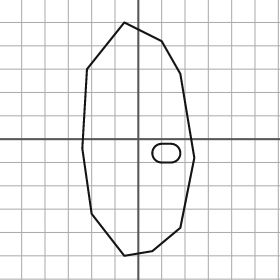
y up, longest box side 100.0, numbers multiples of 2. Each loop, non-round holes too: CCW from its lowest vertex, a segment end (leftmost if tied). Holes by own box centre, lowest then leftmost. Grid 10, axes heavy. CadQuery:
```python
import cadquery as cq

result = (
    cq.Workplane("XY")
    .moveTo(-6.0, -50.0)
    .lineTo(6.0, -48.0)
    .lineTo(18.0, -38.0)
    .lineTo(24.0, -8.0)
    .lineTo(18.0, 28.0)
    .lineTo(10.0, 42.0)
    .lineTo(-6.0, 50.0)
    .lineTo(-22.0, 30.0)
    .lineTo(-24.0, -4.0)
    .lineTo(-20.0, -32.0)
    .close()
    .moveTo(10.0, -10.0)
    .lineTo(14.0, -10.0)
    .threePointArc((18.0, -6.0), (14.0, -2.0))
    .lineTo(10.0, -2.0)
    .threePointArc((6.0, -6.0), (10.0, -10.0))
    .close()
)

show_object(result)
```